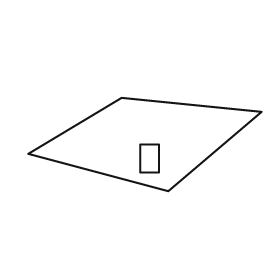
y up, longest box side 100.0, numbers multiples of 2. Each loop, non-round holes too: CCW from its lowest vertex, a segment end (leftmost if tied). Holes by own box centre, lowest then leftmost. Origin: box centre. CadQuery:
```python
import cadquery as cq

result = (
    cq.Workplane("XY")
    .moveTo(10.0, -20.0)
    .lineTo(50.0, 14.0)
    .lineTo(-10.0, 20.0)
    .lineTo(-50.0, -4.0)
    .close()
    .moveTo(-2.0, -12.0)
    .lineTo(6.0, -12.0)
    .lineTo(6.0, 0.0)
    .lineTo(-2.0, 0.0)
    .close()
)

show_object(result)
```